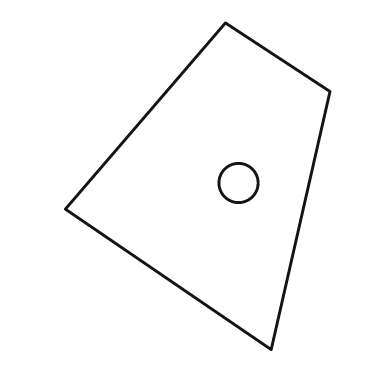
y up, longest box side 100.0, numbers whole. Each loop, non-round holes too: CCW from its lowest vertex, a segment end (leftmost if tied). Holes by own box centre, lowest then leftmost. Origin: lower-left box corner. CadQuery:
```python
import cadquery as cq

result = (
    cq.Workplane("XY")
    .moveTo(63.0, 0.0)
    .lineTo(81.0, 79.0)
    .lineTo(49.0, 100.0)
    .lineTo(0.0, 43.0)
    .close()
    .moveTo(53.0, 51.0)
    .circle(6.0)
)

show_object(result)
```